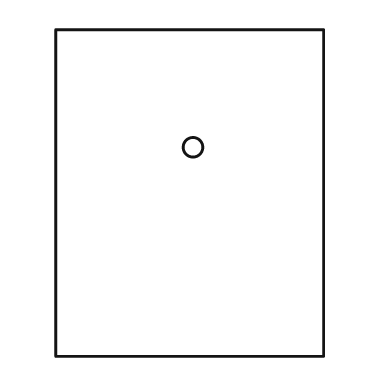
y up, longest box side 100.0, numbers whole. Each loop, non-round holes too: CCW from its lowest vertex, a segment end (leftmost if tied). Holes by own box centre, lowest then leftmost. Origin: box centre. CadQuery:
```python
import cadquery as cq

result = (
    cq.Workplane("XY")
    .moveTo(-41.0, -50.0)
    .lineTo(41.0, -50.0)
    .lineTo(41.0, 50.0)
    .lineTo(-41.0, 50.0)
    .close()
    .moveTo(1.0, 14.0)
    .circle(3.0)
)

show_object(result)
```